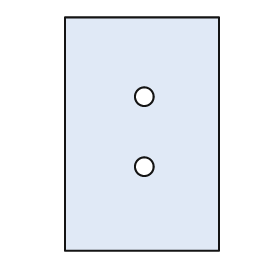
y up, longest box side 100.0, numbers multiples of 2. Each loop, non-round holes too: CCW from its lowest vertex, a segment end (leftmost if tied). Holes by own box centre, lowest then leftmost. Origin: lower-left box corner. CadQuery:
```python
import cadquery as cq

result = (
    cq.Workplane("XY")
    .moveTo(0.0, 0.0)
    .lineTo(66.0, 0.0)
    .lineTo(66.0, 100.0)
    .lineTo(0.0, 100.0)
    .close()
    .moveTo(34.0, 36.0)
    .circle(4.0)
    .moveTo(34.0, 66.0)
    .circle(4.0)
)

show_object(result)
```